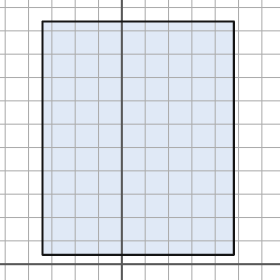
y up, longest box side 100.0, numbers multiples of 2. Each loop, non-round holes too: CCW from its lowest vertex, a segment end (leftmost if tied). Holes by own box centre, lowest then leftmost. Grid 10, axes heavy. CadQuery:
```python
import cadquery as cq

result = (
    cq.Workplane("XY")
    .moveTo(-34.0, 4.0)
    .lineTo(48.0, 4.0)
    .lineTo(48.0, 104.0)
    .lineTo(-34.0, 104.0)
    .close()
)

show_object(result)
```